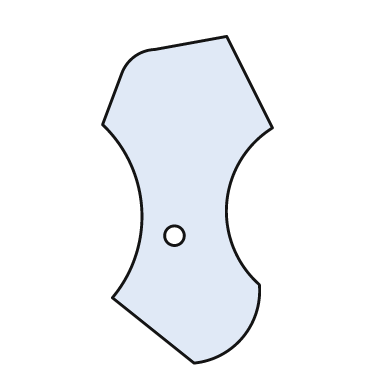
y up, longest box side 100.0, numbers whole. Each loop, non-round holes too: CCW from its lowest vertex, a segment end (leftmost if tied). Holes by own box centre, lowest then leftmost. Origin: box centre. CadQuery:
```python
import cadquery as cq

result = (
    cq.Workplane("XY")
    .moveTo(2.0, -50.0)
    .threePointArc((17.0, -42.0), (22.0, -26.0))
    .threePointArc((12.0, -1.0), (26.0, 22.0))
    .lineTo(12.0, 50.0)
    .lineTo(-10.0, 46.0)
    .threePointArc((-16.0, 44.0), (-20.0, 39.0))
    .lineTo(-26.0, 23.0)
    .threePointArc((-14.0, -3.0), (-23.0, -30.0))
    .close()
    .moveTo(-4.0, -11.0)
    .circle(3.0)
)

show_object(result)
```